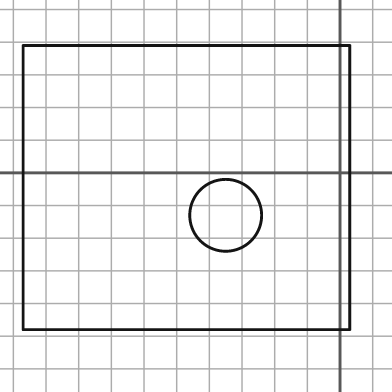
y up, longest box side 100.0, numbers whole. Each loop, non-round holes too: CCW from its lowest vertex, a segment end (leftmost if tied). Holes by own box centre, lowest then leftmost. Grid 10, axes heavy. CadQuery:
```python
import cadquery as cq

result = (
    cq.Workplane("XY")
    .moveTo(-97.0, -48.0)
    .lineTo(3.0, -48.0)
    .lineTo(3.0, 39.0)
    .lineTo(-97.0, 39.0)
    .close()
    .moveTo(-35.0, -13.0)
    .circle(11.0)
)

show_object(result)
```